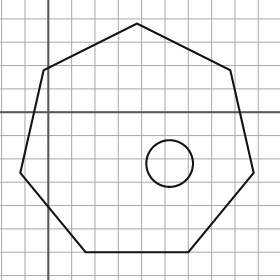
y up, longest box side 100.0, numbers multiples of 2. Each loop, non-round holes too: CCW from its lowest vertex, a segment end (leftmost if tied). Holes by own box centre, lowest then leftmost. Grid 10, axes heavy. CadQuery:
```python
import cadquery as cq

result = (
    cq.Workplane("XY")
    .moveTo(16.0, -60.0)
    .lineTo(60.0, -60.0)
    .lineTo(88.0, -26.0)
    .lineTo(78.0, 18.0)
    .lineTo(38.0, 38.0)
    .lineTo(-2.0, 18.0)
    .lineTo(-12.0, -26.0)
    .close()
    .moveTo(52.0, -22.0)
    .circle(10.0)
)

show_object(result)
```